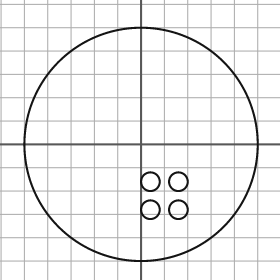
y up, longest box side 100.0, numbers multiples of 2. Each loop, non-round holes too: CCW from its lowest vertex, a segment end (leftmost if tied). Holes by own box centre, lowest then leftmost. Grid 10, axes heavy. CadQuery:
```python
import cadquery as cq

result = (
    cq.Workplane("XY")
    .moveTo(0.0, 0.0)
    .circle(50.0)
    .moveTo(4.0, -28.0)
    .circle(4.0)
    .moveTo(16.0, -28.0)
    .circle(4.0)
    .moveTo(4.0, -16.0)
    .circle(4.0)
    .moveTo(16.0, -16.0)
    .circle(4.0)
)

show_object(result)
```